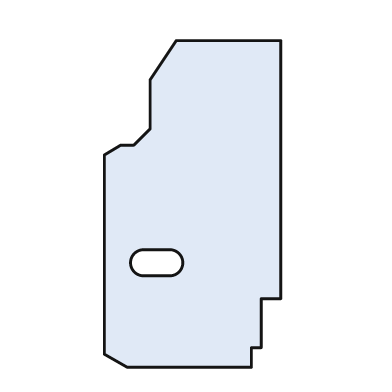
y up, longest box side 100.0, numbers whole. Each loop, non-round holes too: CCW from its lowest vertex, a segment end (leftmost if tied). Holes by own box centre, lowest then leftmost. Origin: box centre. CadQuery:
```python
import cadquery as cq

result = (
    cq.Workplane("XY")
    .moveTo(-20.0, -50.0)
    .lineTo(18.0, -50.0)
    .lineTo(18.0, -44.0)
    .lineTo(21.0, -44.0)
    .lineTo(21.0, -29.0)
    .lineTo(27.0, -29.0)
    .lineTo(27.0, 50.0)
    .lineTo(-5.0, 50.0)
    .lineTo(-13.0, 38.0)
    .lineTo(-13.0, 23.0)
    .lineTo(-18.0, 18.0)
    .lineTo(-22.0, 18.0)
    .lineTo(-27.0, 15.0)
    .lineTo(-27.0, -46.0)
    .close()
    .moveTo(-15.0, -22.0)
    .lineTo(-7.0, -22.0)
    .threePointArc((-3.0, -18.0), (-7.0, -14.0))
    .lineTo(-15.0, -14.0)
    .threePointArc((-19.0, -18.0), (-15.0, -22.0))
    .close()
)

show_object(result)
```